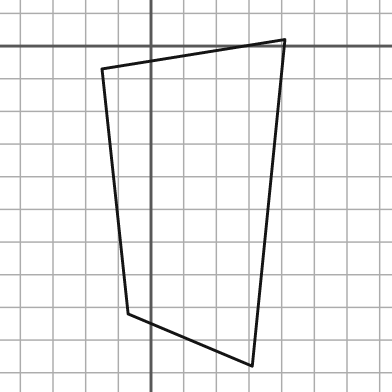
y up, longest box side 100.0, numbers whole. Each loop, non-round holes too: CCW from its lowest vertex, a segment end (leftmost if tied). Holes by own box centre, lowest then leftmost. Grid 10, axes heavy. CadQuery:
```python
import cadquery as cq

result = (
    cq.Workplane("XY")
    .moveTo(31.0, -98.0)
    .lineTo(41.0, 2.0)
    .lineTo(-15.0, -7.0)
    .lineTo(-7.0, -82.0)
    .close()
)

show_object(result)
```